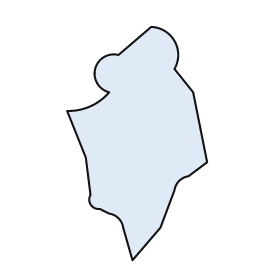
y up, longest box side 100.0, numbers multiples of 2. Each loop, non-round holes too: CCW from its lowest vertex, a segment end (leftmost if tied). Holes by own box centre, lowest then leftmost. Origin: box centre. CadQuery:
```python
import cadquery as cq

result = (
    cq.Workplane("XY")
    .moveTo(-2.0, -50.0)
    .lineTo(10.0, -36.0)
    .lineTo(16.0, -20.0)
    .threePointArc((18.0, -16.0), (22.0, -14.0))
    .lineTo(30.0, -8.0)
    .lineTo(24.0, 22.0)
    .lineTo(16.0, 32.0)
    .threePointArc((16.0, 44.0), (6.0, 50.0))
    .lineTo(-8.0, 38.0)
    .threePointArc((-18.0, 32.0), (-12.0, 22.0))
    .threePointArc((-20.0, 16.0), (-30.0, 14.0))
    .lineTo(-22.0, -6.0)
    .lineTo(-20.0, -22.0)
    .threePointArc((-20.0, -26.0), (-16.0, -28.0))
    .lineTo(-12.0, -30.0)
    .threePointArc((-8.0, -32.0), (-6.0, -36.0))
    .close()
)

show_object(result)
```